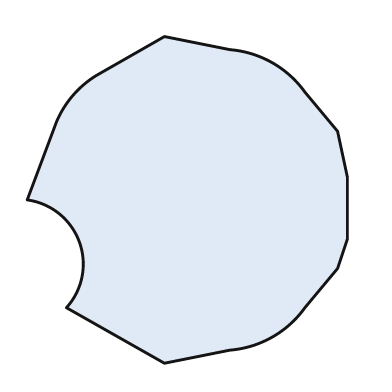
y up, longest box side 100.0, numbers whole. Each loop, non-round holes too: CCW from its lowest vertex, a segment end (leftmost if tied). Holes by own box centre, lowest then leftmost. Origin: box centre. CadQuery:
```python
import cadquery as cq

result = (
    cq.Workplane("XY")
    .moveTo(-7.0, -50.0)
    .lineTo(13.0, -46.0)
    .threePointArc((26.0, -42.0), (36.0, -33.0))
    .lineTo(46.0, -21.0)
    .lineTo(49.0, -12.0)
    .lineTo(49.0, 7.0)
    .lineTo(46.0, 21.0)
    .lineTo(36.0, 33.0)
    .threePointArc((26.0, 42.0), (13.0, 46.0))
    .lineTo(-7.0, 50.0)
    .lineTo(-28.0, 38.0)
    .threePointArc((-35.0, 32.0), (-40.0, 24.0))
    .lineTo(-49.0, 0.0)
    .threePointArc((-33.0, -13.0), (-37.0, -33.0))
    .close()
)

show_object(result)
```